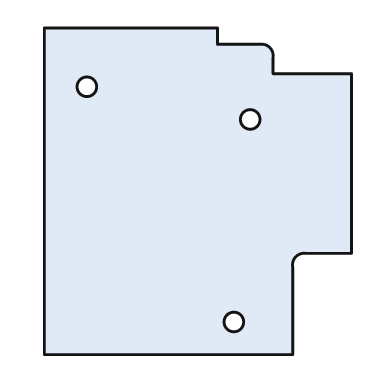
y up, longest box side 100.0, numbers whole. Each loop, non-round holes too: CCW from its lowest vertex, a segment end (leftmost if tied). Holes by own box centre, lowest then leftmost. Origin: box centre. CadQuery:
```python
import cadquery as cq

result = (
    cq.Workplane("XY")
    .moveTo(-47.0, -50.0)
    .lineTo(29.0, -50.0)
    .lineTo(29.0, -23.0)
    .threePointArc((30.0, -20.0), (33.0, -19.0))
    .lineTo(47.0, -19.0)
    .lineTo(47.0, 36.0)
    .lineTo(23.0, 36.0)
    .lineTo(23.0, 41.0)
    .threePointArc((22.0, 44.0), (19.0, 45.0))
    .lineTo(6.0, 45.0)
    .lineTo(6.0, 50.0)
    .lineTo(-47.0, 50.0)
    .close()
    .moveTo(11.0, -40.0)
    .circle(3.0)
    .moveTo(16.0, 22.0)
    .circle(3.0)
    .moveTo(-34.0, 32.0)
    .circle(3.0)
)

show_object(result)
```